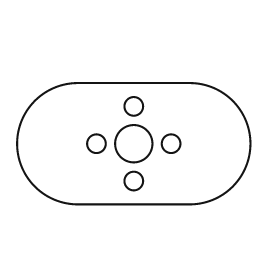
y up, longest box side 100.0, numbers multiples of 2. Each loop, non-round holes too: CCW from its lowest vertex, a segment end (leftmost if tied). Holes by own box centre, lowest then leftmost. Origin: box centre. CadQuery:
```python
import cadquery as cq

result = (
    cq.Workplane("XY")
    .moveTo(-24.0, -26.0)
    .lineTo(24.0, -26.0)
    .threePointArc((50.0, 0.0), (24.0, 26.0))
    .lineTo(-24.0, 26.0)
    .threePointArc((-50.0, 0.0), (-24.0, -26.0))
    .close()
    .moveTo(0.0, -16.0)
    .circle(4.0)
    .moveTo(-16.0, 0.0)
    .circle(4.0)
    .moveTo(0.0, 0.0)
    .circle(8.0)
    .moveTo(16.0, 0.0)
    .circle(4.0)
    .moveTo(0.0, 16.0)
    .circle(4.0)
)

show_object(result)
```